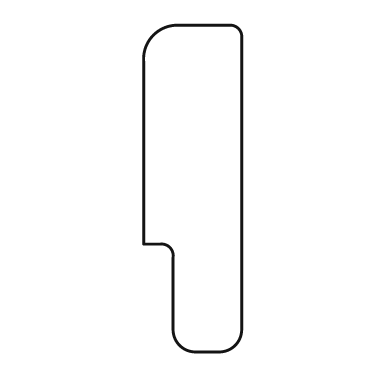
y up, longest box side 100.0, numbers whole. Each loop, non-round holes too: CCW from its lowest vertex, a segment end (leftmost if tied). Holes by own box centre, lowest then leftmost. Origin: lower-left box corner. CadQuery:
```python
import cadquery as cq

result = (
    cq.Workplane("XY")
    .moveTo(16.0, 0.0)
    .lineTo(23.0, 0.0)
    .threePointArc((28.0, 2.0), (30.0, 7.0))
    .lineTo(30.0, 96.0)
    .threePointArc((29.0, 99.0), (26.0, 100.0))
    .lineTo(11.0, 100.0)
    .threePointArc((3.0, 97.0), (0.0, 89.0))
    .lineTo(0.0, 33.0)
    .lineTo(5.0, 33.0)
    .threePointArc((8.0, 32.0), (9.0, 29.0))
    .lineTo(9.0, 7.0)
    .threePointArc((11.0, 2.0), (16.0, 0.0))
    .close()
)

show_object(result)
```